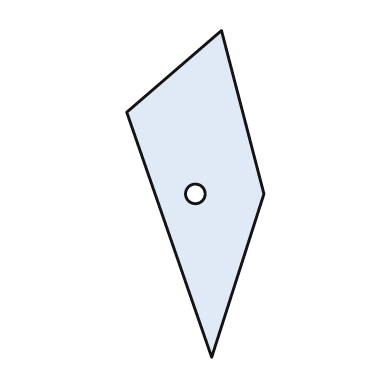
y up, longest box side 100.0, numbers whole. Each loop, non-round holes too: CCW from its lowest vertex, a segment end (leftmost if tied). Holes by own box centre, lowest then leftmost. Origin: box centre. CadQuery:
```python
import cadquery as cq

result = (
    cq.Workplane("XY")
    .moveTo(5.0, -50.0)
    .lineTo(21.0, 0.0)
    .lineTo(8.0, 50.0)
    .lineTo(-21.0, 25.0)
    .close()
    .moveTo(0.0, 0.0)
    .circle(3.0)
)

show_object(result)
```